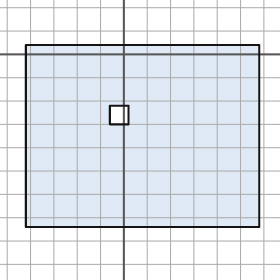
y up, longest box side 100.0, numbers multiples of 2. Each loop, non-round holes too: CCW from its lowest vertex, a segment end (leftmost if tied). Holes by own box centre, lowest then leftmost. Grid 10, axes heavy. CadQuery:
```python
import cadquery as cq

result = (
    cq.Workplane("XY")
    .moveTo(-42.0, -74.0)
    .lineTo(58.0, -74.0)
    .lineTo(58.0, 4.0)
    .lineTo(-42.0, 4.0)
    .close()
    .moveTo(-6.0, -30.0)
    .lineTo(2.0, -30.0)
    .lineTo(2.0, -22.0)
    .lineTo(-6.0, -22.0)
    .close()
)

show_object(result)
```